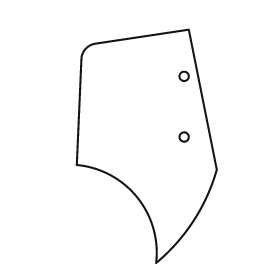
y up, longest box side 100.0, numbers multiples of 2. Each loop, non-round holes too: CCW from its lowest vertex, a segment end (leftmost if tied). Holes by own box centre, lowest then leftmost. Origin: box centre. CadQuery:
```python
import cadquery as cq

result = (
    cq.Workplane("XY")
    .moveTo(4.0, -50.0)
    .threePointArc((20.0, -32.0), (30.0, -10.0))
    .lineTo(18.0, 50.0)
    .lineTo(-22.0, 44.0)
    .threePointArc((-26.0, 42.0), (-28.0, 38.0))
    .lineTo(-30.0, -8.0)
    .threePointArc((-4.0, -22.0), (4.0, -50.0))
    .close()
    .moveTo(16.0, 4.0)
    .circle(2.0)
    .moveTo(16.0, 30.0)
    .circle(2.0)
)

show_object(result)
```